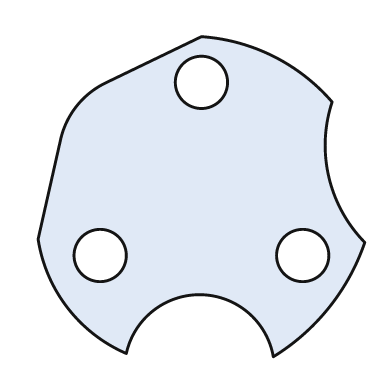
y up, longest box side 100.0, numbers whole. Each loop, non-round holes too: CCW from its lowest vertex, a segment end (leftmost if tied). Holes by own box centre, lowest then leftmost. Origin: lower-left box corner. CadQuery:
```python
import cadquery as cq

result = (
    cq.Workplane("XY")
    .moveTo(72.0, 0.0)
    .threePointArc((89.0, 15.0), (100.0, 35.0))
    .threePointArc((89.0, 55.0), (90.0, 78.0))
    .threePointArc((72.0, 92.0), (50.0, 98.0))
    .lineTo(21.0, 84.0)
    .threePointArc((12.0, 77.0), (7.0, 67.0))
    .lineTo(0.0, 36.0)
    .threePointArc((9.0, 15.0), (27.0, 1.0))
    .threePointArc((50.0, 19.0), (72.0, 0.0))
    .close()
    .moveTo(19.0, 31.0)
    .circle(8.0)
    .moveTo(81.0, 31.0)
    .circle(8.0)
    .moveTo(50.0, 84.0)
    .circle(8.0)
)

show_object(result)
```